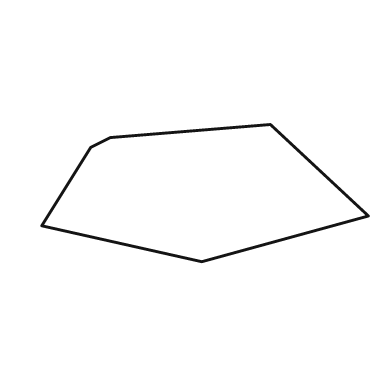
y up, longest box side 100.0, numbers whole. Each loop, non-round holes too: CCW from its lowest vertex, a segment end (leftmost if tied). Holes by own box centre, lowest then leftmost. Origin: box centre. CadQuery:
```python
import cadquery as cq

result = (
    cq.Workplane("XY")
    .moveTo(-1.0, -21.0)
    .lineTo(50.0, -7.0)
    .lineTo(20.0, 21.0)
    .lineTo(-29.0, 17.0)
    .lineTo(-35.0, 14.0)
    .lineTo(-50.0, -10.0)
    .close()
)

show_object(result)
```